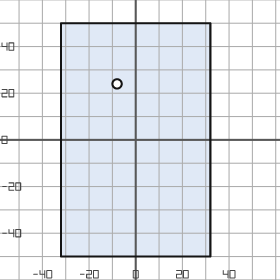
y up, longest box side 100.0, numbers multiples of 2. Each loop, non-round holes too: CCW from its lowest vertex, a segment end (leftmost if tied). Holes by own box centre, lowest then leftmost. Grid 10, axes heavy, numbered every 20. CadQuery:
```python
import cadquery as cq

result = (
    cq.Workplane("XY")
    .moveTo(-32.0, -50.0)
    .lineTo(32.0, -50.0)
    .lineTo(32.0, 50.0)
    .lineTo(-32.0, 50.0)
    .close()
    .moveTo(-8.0, 24.0)
    .circle(2.0)
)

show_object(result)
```